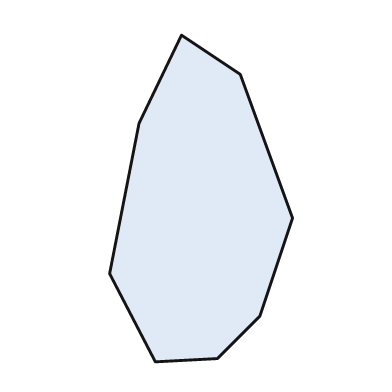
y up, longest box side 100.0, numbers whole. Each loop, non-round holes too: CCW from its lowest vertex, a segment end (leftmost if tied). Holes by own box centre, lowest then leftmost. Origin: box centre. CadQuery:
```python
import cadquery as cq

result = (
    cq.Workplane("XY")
    .moveTo(-14.0, -50.0)
    .lineTo(5.0, -49.0)
    .lineTo(18.0, -36.0)
    .lineTo(28.0, -6.0)
    .lineTo(12.0, 38.0)
    .lineTo(-6.0, 50.0)
    .lineTo(-19.0, 23.0)
    .lineTo(-28.0, -23.0)
    .close()
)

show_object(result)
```